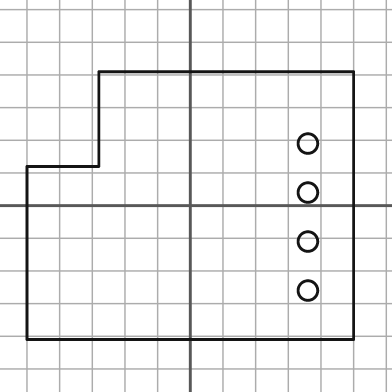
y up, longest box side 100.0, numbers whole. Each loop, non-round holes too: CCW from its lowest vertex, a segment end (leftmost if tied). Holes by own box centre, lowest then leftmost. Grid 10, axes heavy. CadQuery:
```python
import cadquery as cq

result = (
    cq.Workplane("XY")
    .moveTo(-50.0, -41.0)
    .lineTo(50.0, -41.0)
    .lineTo(50.0, 41.0)
    .lineTo(-28.0, 41.0)
    .lineTo(-28.0, 12.0)
    .lineTo(-50.0, 12.0)
    .close()
    .moveTo(36.0, -26.0)
    .circle(3.0)
    .moveTo(36.0, -11.0)
    .circle(3.0)
    .moveTo(36.0, 4.0)
    .circle(3.0)
    .moveTo(36.0, 19.0)
    .circle(3.0)
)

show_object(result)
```